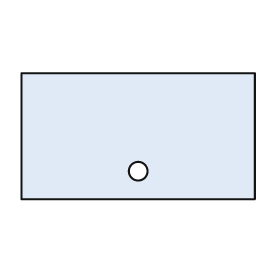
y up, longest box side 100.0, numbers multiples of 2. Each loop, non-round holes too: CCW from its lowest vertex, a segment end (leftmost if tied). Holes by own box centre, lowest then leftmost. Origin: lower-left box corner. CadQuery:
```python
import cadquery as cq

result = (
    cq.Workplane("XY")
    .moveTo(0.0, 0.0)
    .lineTo(100.0, 0.0)
    .lineTo(100.0, 54.0)
    .lineTo(0.0, 54.0)
    .close()
    .moveTo(50.0, 12.0)
    .circle(4.0)
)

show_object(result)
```